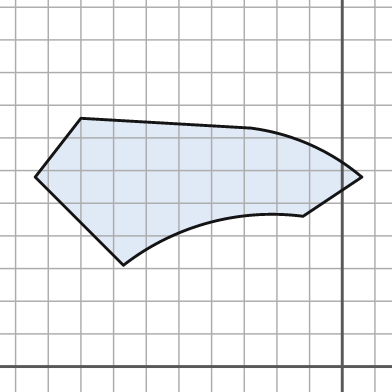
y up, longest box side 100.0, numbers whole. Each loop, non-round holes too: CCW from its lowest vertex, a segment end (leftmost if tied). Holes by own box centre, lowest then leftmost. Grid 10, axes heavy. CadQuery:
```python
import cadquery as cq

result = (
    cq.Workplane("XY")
    .moveTo(-67.0, 31.0)
    .threePointArc((-41.0, 44.0), (-12.0, 46.0))
    .lineTo(6.0, 58.0)
    .threePointArc((-10.0, 68.0), (-28.0, 73.0))
    .lineTo(-80.0, 76.0)
    .lineTo(-94.0, 58.0)
    .close()
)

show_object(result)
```